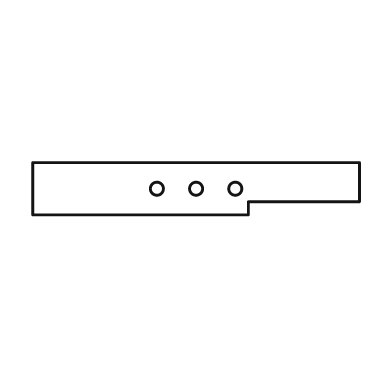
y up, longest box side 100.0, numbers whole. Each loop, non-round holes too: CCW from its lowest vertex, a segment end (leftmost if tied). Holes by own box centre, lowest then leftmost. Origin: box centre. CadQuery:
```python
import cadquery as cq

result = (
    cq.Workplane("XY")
    .moveTo(-50.0, -8.0)
    .lineTo(16.0, -8.0)
    .lineTo(16.0, -4.0)
    .lineTo(50.0, -4.0)
    .lineTo(50.0, 8.0)
    .lineTo(-50.0, 8.0)
    .close()
    .moveTo(-12.0, 0.0)
    .circle(2.0)
    .moveTo(0.0, 0.0)
    .circle(2.0)
    .moveTo(12.0, 0.0)
    .circle(2.0)
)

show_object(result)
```